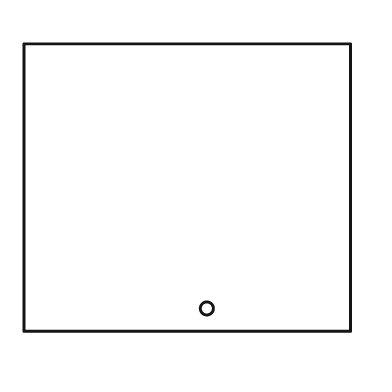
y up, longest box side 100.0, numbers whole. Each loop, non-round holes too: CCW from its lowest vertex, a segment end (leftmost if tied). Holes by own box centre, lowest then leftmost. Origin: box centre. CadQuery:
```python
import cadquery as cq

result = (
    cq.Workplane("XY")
    .moveTo(-50.0, -44.0)
    .lineTo(50.0, -44.0)
    .lineTo(50.0, 44.0)
    .lineTo(-50.0, 44.0)
    .close()
    .moveTo(6.0, -37.0)
    .circle(2.0)
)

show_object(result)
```